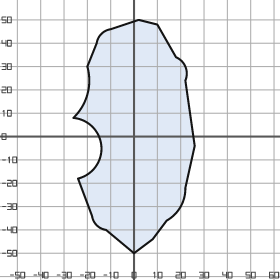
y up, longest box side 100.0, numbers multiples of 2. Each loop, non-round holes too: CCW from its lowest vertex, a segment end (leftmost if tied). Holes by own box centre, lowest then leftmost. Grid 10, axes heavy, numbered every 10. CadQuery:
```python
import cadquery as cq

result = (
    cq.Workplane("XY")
    .moveTo(0.0, -50.0)
    .lineTo(8.0, -44.0)
    .lineTo(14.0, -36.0)
    .threePointArc((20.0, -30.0), (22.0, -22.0))
    .lineTo(26.0, -4.0)
    .lineTo(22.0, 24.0)
    .threePointArc((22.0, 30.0), (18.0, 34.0))
    .lineTo(10.0, 48.0)
    .lineTo(2.0, 50.0)
    .lineTo(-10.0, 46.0)
    .threePointArc((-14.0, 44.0), (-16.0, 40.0))
    .lineTo(-20.0, 30.0)
    .threePointArc((-20.0, 18.0), (-26.0, 8.0))
    .threePointArc((-14.0, -4.0), (-24.0, -18.0))
    .lineTo(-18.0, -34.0)
    .threePointArc((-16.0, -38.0), (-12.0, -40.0))
    .close()
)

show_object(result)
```